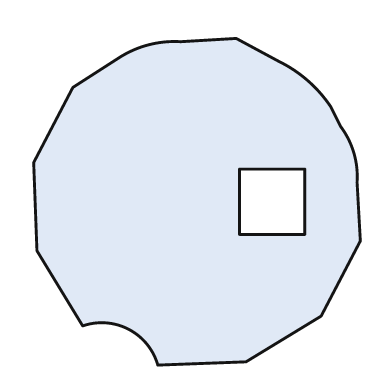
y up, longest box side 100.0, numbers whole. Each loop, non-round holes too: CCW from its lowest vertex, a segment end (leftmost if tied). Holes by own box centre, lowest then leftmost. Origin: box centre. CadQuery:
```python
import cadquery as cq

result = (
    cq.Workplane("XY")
    .moveTo(-12.0, -50.0)
    .lineTo(15.0, -49.0)
    .lineTo(38.0, -35.0)
    .lineTo(50.0, -12.0)
    .lineTo(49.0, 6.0)
    .threePointArc((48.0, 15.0), (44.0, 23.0))
    .lineTo(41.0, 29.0)
    .threePointArc((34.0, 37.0), (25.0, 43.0))
    .lineTo(12.0, 50.0)
    .lineTo(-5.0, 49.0)
    .threePointArc((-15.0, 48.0), (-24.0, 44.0))
    .lineTo(-38.0, 35.0)
    .lineTo(-50.0, 12.0)
    .lineTo(-49.0, -15.0)
    .lineTo(-35.0, -38.0)
    .threePointArc((-21.0, -39.0), (-12.0, -50.0))
    .close()
    .moveTo(13.0, -10.0)
    .lineTo(33.0, -10.0)
    .lineTo(33.0, 10.0)
    .lineTo(13.0, 10.0)
    .close()
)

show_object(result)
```